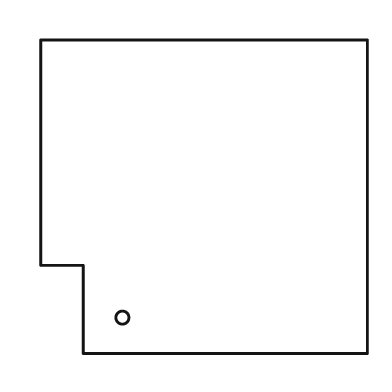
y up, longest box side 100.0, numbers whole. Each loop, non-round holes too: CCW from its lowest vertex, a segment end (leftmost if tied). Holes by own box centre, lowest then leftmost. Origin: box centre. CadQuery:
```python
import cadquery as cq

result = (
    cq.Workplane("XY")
    .moveTo(-37.0, -48.0)
    .lineTo(50.0, -48.0)
    .lineTo(50.0, 48.0)
    .lineTo(-50.0, 48.0)
    .lineTo(-50.0, -21.0)
    .lineTo(-37.0, -21.0)
    .close()
    .moveTo(-25.0, -37.0)
    .circle(2.0)
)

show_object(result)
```